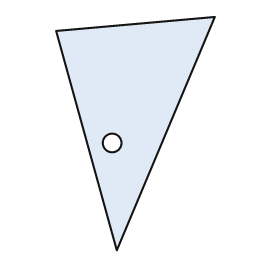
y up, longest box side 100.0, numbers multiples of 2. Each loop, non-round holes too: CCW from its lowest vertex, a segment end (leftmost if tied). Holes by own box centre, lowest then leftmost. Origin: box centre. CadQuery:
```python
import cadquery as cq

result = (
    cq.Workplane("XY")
    .moveTo(-8.0, -50.0)
    .lineTo(34.0, 50.0)
    .lineTo(-34.0, 44.0)
    .close()
    .moveTo(-10.0, -4.0)
    .circle(4.0)
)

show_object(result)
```